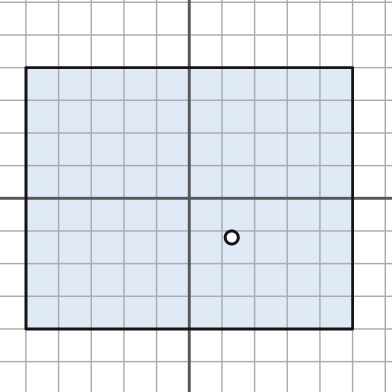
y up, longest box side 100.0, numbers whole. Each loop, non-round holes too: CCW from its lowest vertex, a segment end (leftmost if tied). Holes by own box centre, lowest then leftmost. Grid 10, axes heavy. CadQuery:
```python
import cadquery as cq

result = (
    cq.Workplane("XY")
    .moveTo(-50.0, -40.0)
    .lineTo(50.0, -40.0)
    .lineTo(50.0, 40.0)
    .lineTo(-50.0, 40.0)
    .close()
    .moveTo(13.0, -12.0)
    .circle(2.0)
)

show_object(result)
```